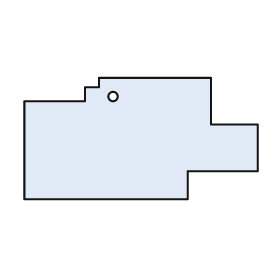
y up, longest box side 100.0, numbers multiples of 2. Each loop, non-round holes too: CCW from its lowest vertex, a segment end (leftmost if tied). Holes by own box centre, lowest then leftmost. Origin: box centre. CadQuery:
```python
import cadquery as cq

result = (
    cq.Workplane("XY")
    .moveTo(-50.0, -26.0)
    .lineTo(20.0, -26.0)
    .lineTo(20.0, -14.0)
    .lineTo(50.0, -14.0)
    .lineTo(50.0, 6.0)
    .lineTo(30.0, 6.0)
    .lineTo(30.0, 26.0)
    .lineTo(-18.0, 26.0)
    .lineTo(-18.0, 22.0)
    .lineTo(-24.0, 22.0)
    .lineTo(-24.0, 16.0)
    .lineTo(-50.0, 16.0)
    .close()
    .moveTo(-12.0, 18.0)
    .circle(2.0)
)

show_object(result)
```